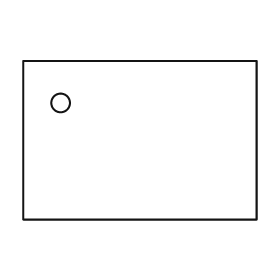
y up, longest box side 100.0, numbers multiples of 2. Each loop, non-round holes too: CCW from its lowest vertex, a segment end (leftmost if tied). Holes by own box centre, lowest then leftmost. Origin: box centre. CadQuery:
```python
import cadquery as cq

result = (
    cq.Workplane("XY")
    .moveTo(-50.0, -34.0)
    .lineTo(50.0, -34.0)
    .lineTo(50.0, 34.0)
    .lineTo(-50.0, 34.0)
    .close()
    .moveTo(-34.0, 16.0)
    .circle(4.0)
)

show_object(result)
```